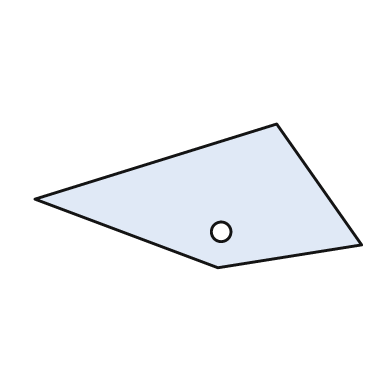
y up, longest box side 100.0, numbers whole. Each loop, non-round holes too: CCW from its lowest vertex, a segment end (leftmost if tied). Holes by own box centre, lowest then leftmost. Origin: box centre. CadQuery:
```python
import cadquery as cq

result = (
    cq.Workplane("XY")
    .moveTo(6.0, -22.0)
    .lineTo(50.0, -15.0)
    .lineTo(24.0, 22.0)
    .lineTo(-50.0, -1.0)
    .close()
    .moveTo(7.0, -11.0)
    .circle(3.0)
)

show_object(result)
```